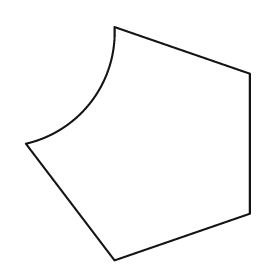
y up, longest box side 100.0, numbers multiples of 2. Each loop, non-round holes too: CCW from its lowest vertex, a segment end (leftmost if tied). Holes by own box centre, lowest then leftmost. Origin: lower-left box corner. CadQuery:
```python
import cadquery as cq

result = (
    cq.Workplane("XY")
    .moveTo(38.0, 0.0)
    .lineTo(96.0, 20.0)
    .lineTo(96.0, 80.0)
    .lineTo(38.0, 100.0)
    .threePointArc((28.0, 68.0), (0.0, 50.0))
    .close()
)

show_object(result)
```